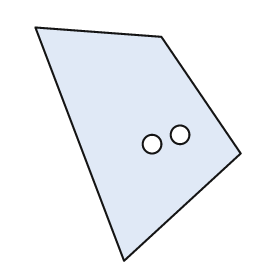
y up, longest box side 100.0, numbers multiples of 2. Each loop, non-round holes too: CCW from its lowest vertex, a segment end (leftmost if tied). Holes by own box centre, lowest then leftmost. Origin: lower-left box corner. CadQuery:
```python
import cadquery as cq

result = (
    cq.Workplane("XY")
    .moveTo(38.0, 0.0)
    .lineTo(88.0, 46.0)
    .lineTo(54.0, 96.0)
    .lineTo(0.0, 100.0)
    .close()
    .moveTo(50.0, 50.0)
    .circle(4.0)
    .moveTo(62.0, 54.0)
    .circle(4.0)
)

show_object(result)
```